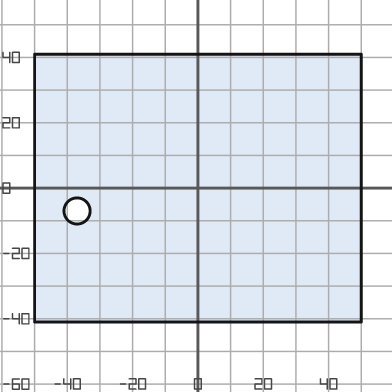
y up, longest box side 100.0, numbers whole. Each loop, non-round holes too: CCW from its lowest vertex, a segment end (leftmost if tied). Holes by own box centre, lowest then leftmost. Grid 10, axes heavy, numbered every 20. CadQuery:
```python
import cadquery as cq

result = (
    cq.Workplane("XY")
    .moveTo(-50.0, -41.0)
    .lineTo(50.0, -41.0)
    .lineTo(50.0, 41.0)
    .lineTo(-50.0, 41.0)
    .close()
    .moveTo(-37.0, -7.0)
    .circle(4.0)
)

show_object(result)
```